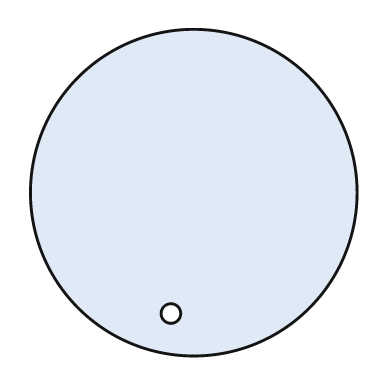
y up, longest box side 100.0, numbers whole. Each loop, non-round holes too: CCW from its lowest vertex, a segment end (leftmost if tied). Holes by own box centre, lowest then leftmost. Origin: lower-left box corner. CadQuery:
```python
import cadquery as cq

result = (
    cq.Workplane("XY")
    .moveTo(50.0, 50.0)
    .circle(50.0)
    .moveTo(43.0, 13.0)
    .circle(3.0)
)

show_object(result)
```